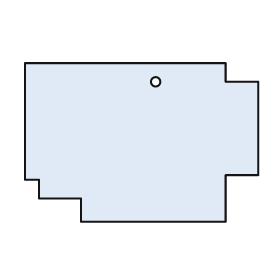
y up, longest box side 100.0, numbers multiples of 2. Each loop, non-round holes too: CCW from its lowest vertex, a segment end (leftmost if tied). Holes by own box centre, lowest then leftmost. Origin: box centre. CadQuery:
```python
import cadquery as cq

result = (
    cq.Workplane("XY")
    .moveTo(-26.0, -34.0)
    .lineTo(36.0, -34.0)
    .lineTo(36.0, -14.0)
    .lineTo(50.0, -14.0)
    .lineTo(50.0, 26.0)
    .lineTo(36.0, 26.0)
    .lineTo(36.0, 34.0)
    .lineTo(-50.0, 34.0)
    .lineTo(-50.0, -16.0)
    .lineTo(-44.0, -16.0)
    .lineTo(-44.0, -24.0)
    .lineTo(-26.0, -24.0)
    .close()
    .moveTo(6.0, 26.0)
    .circle(2.0)
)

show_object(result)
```